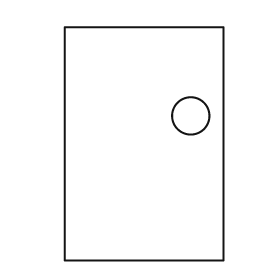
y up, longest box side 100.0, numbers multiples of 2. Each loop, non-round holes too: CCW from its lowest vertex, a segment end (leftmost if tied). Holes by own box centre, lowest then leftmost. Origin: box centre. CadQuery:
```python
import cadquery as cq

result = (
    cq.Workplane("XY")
    .moveTo(-34.0, -50.0)
    .lineTo(34.0, -50.0)
    .lineTo(34.0, 50.0)
    .lineTo(-34.0, 50.0)
    .close()
    .moveTo(20.0, 12.0)
    .circle(8.0)
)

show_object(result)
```